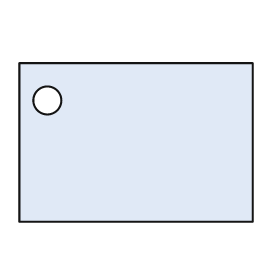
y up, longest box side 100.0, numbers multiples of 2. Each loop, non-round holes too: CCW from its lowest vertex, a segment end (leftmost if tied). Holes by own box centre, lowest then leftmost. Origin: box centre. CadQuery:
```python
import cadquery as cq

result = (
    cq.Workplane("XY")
    .moveTo(-50.0, -34.0)
    .lineTo(50.0, -34.0)
    .lineTo(50.0, 34.0)
    .lineTo(-50.0, 34.0)
    .close()
    .moveTo(-38.0, 18.0)
    .circle(6.0)
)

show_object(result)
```